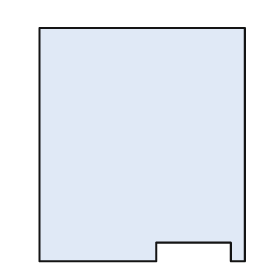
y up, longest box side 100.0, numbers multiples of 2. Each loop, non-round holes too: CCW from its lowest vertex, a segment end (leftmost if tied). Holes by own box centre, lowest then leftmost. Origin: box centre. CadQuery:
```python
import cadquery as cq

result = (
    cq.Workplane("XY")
    .moveTo(-44.0, -50.0)
    .lineTo(6.0, -50.0)
    .lineTo(6.0, -42.0)
    .lineTo(38.0, -42.0)
    .lineTo(38.0, -50.0)
    .lineTo(44.0, -50.0)
    .lineTo(44.0, 50.0)
    .lineTo(-44.0, 50.0)
    .close()
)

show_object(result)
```